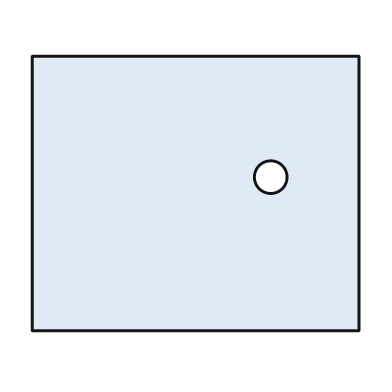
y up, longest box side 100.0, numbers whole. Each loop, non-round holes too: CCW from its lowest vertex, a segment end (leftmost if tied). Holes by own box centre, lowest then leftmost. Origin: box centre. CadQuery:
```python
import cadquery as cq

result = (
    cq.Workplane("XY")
    .moveTo(-50.0, -42.0)
    .lineTo(50.0, -42.0)
    .lineTo(50.0, 42.0)
    .lineTo(-50.0, 42.0)
    .close()
    .moveTo(23.0, 5.0)
    .circle(5.0)
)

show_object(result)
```